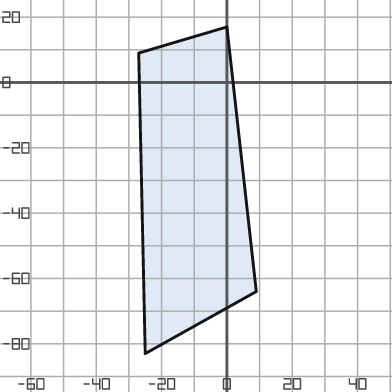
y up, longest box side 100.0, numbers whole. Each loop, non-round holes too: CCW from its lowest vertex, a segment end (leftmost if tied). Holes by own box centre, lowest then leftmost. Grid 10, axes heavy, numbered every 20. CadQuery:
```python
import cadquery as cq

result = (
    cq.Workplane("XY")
    .moveTo(-25.0, -83.0)
    .lineTo(9.0, -64.0)
    .lineTo(0.0, 17.0)
    .lineTo(-27.0, 9.0)
    .close()
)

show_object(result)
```